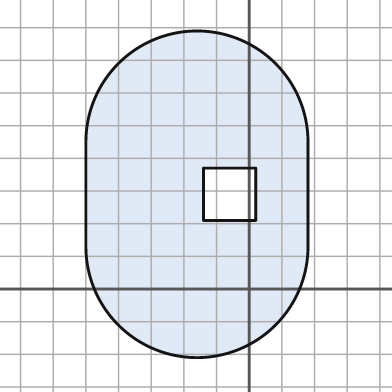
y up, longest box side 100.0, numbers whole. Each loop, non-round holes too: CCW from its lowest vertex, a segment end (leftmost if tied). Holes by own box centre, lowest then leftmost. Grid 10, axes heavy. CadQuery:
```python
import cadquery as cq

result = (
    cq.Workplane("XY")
    .moveTo(-50.0, 13.0)
    .threePointArc((-16.0, -21.0), (18.0, 13.0))
    .lineTo(18.0, 45.0)
    .threePointArc((-16.0, 79.0), (-50.0, 45.0))
    .close()
    .moveTo(-14.0, 21.0)
    .lineTo(2.0, 21.0)
    .lineTo(2.0, 37.0)
    .lineTo(-14.0, 37.0)
    .close()
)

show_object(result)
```